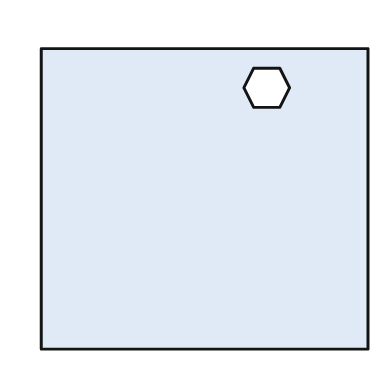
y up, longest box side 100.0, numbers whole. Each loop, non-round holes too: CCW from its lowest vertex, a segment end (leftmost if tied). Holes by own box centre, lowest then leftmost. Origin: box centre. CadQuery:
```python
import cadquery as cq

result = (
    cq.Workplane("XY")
    .moveTo(-50.0, -46.0)
    .lineTo(50.0, -46.0)
    .lineTo(50.0, 46.0)
    .lineTo(-50.0, 46.0)
    .close()
    .moveTo(15.0, 28.0)
    .lineTo(23.0, 28.0)
    .lineTo(26.0, 34.0)
    .lineTo(23.0, 40.0)
    .lineTo(15.0, 40.0)
    .lineTo(12.0, 34.0)
    .close()
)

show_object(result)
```